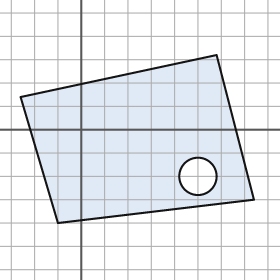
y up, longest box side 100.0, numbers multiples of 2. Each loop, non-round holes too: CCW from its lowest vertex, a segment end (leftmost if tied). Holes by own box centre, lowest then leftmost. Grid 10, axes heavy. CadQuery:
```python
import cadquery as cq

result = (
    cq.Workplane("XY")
    .moveTo(-10.0, -40.0)
    .lineTo(74.0, -30.0)
    .lineTo(58.0, 32.0)
    .lineTo(-26.0, 14.0)
    .close()
    .moveTo(50.0, -20.0)
    .circle(8.0)
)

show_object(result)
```